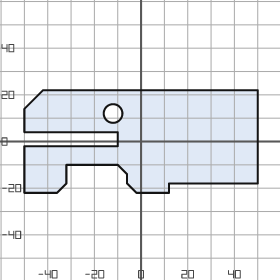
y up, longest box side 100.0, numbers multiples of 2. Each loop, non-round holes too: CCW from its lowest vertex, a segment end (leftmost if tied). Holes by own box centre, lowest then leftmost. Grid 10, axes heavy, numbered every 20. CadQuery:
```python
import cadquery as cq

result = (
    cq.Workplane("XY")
    .moveTo(-50.0, -22.0)
    .lineTo(-36.0, -22.0)
    .lineTo(-32.0, -18.0)
    .lineTo(-32.0, -10.0)
    .lineTo(-10.0, -10.0)
    .lineTo(-6.0, -14.0)
    .lineTo(-6.0, -18.0)
    .lineTo(-2.0, -22.0)
    .lineTo(12.0, -22.0)
    .lineTo(12.0, -18.0)
    .lineTo(50.0, -18.0)
    .lineTo(50.0, 22.0)
    .lineTo(-42.0, 22.0)
    .lineTo(-50.0, 14.0)
    .lineTo(-50.0, 4.0)
    .lineTo(-10.0, 4.0)
    .lineTo(-10.0, -2.0)
    .lineTo(-50.0, -2.0)
    .close()
    .moveTo(-12.0, 12.0)
    .circle(4.0)
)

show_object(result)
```